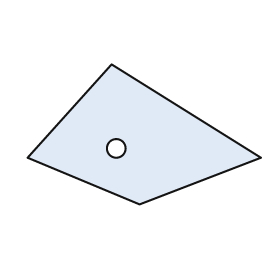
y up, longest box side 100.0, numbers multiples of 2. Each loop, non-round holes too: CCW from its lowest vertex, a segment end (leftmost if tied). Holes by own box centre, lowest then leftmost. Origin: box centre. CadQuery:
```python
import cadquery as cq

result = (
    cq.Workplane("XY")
    .moveTo(-2.0, -30.0)
    .lineTo(50.0, -10.0)
    .lineTo(-14.0, 30.0)
    .lineTo(-50.0, -10.0)
    .close()
    .moveTo(-12.0, -6.0)
    .circle(4.0)
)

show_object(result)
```